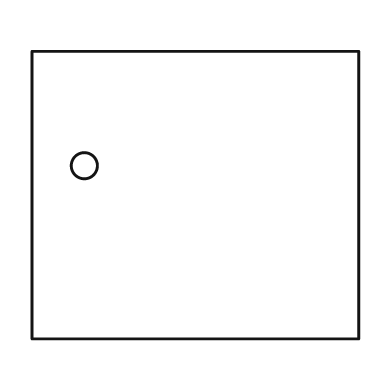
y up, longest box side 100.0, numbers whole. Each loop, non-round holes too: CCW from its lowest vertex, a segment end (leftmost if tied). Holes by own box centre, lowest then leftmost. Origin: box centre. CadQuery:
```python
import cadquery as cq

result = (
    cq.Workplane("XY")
    .moveTo(-50.0, -44.0)
    .lineTo(50.0, -44.0)
    .lineTo(50.0, 44.0)
    .lineTo(-50.0, 44.0)
    .close()
    .moveTo(-34.0, 9.0)
    .circle(4.0)
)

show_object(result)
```